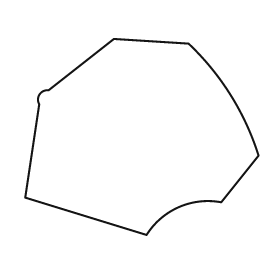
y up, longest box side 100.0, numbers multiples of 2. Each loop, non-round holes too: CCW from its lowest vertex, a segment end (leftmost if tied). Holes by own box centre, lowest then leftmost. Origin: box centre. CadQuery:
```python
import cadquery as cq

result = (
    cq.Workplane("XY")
    .moveTo(2.0, -42.0)
    .threePointArc((16.0, -30.0), (34.0, -28.0))
    .lineTo(50.0, -8.0)
    .threePointArc((38.0, 18.0), (20.0, 40.0))
    .lineTo(-12.0, 42.0)
    .lineTo(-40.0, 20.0)
    .threePointArc((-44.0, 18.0), (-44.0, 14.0))
    .lineTo(-50.0, -26.0)
    .close()
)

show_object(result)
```